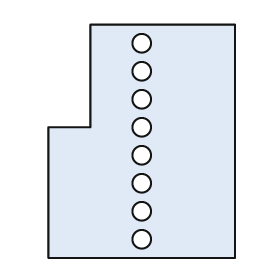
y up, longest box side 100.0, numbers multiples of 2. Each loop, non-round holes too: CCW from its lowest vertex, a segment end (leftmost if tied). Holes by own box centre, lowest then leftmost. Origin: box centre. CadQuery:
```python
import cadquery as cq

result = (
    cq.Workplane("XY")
    .moveTo(-40.0, -50.0)
    .lineTo(40.0, -50.0)
    .lineTo(40.0, 50.0)
    .lineTo(-22.0, 50.0)
    .lineTo(-22.0, 6.0)
    .lineTo(-40.0, 6.0)
    .close()
    .moveTo(0.0, -42.0)
    .circle(4.0)
    .moveTo(0.0, -30.0)
    .circle(4.0)
    .moveTo(0.0, -18.0)
    .circle(4.0)
    .moveTo(0.0, -6.0)
    .circle(4.0)
    .moveTo(0.0, 6.0)
    .circle(4.0)
    .moveTo(0.0, 18.0)
    .circle(4.0)
    .moveTo(0.0, 30.0)
    .circle(4.0)
    .moveTo(0.0, 42.0)
    .circle(4.0)
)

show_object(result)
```